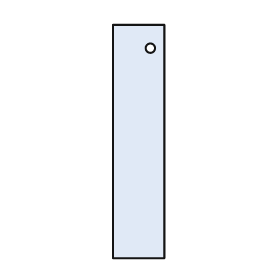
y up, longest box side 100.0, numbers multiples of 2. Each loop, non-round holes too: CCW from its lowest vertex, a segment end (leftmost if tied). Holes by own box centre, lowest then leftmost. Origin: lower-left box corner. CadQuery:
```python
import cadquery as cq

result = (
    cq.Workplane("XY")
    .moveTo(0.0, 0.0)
    .lineTo(22.0, 0.0)
    .lineTo(22.0, 100.0)
    .lineTo(0.0, 100.0)
    .close()
    .moveTo(16.0, 90.0)
    .circle(2.0)
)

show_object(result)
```